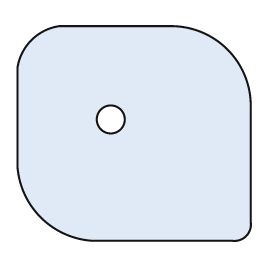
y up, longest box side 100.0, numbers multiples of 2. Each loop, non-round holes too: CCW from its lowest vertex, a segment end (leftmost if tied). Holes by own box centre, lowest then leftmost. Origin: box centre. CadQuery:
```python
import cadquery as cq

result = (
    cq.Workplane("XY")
    .moveTo(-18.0, -46.0)
    .lineTo(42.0, -46.0)
    .threePointArc((48.0, -44.0), (50.0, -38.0))
    .lineTo(50.0, 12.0)
    .threePointArc((40.0, 36.0), (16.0, 46.0))
    .lineTo(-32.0, 46.0)
    .threePointArc((-44.0, 40.0), (-50.0, 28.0))
    .lineTo(-50.0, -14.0)
    .threePointArc((-40.0, -36.0), (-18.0, -46.0))
    .close()
    .moveTo(-10.0, 6.0)
    .circle(6.0)
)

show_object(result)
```